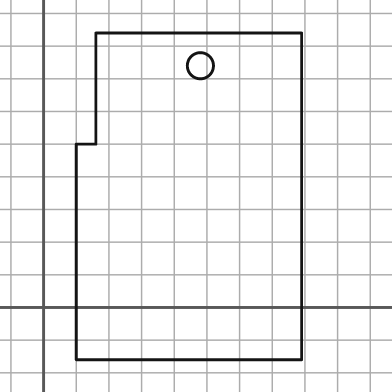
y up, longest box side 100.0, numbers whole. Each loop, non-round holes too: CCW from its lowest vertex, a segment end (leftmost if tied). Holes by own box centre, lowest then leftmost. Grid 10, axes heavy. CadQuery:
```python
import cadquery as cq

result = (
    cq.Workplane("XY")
    .moveTo(10.0, -16.0)
    .lineTo(79.0, -16.0)
    .lineTo(79.0, 84.0)
    .lineTo(16.0, 84.0)
    .lineTo(16.0, 50.0)
    .lineTo(10.0, 50.0)
    .close()
    .moveTo(48.0, 74.0)
    .circle(4.0)
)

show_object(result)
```